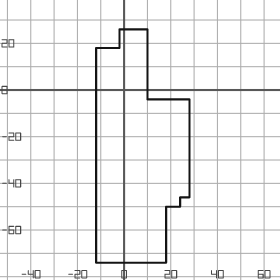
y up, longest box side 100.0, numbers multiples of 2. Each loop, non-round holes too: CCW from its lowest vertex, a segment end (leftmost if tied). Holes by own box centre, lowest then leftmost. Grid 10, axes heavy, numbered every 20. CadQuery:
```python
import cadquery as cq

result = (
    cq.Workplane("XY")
    .moveTo(-12.0, -74.0)
    .lineTo(18.0, -74.0)
    .lineTo(18.0, -50.0)
    .lineTo(24.0, -50.0)
    .lineTo(24.0, -46.0)
    .lineTo(28.0, -46.0)
    .lineTo(28.0, -4.0)
    .lineTo(10.0, -4.0)
    .lineTo(10.0, 26.0)
    .lineTo(-2.0, 26.0)
    .lineTo(-2.0, 18.0)
    .lineTo(-12.0, 18.0)
    .close()
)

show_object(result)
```